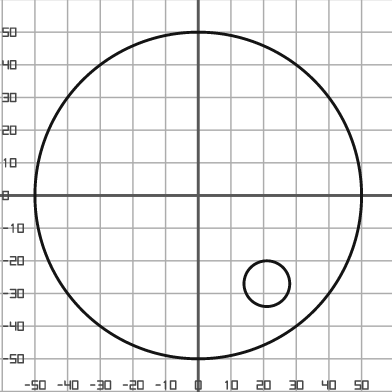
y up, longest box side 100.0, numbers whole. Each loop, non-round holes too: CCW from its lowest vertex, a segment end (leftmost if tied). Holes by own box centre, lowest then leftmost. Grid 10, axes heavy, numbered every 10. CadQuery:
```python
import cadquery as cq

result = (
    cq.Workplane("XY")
    .moveTo(0.0, 0.0)
    .circle(50.0)
    .moveTo(21.0, -27.0)
    .circle(7.0)
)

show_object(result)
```